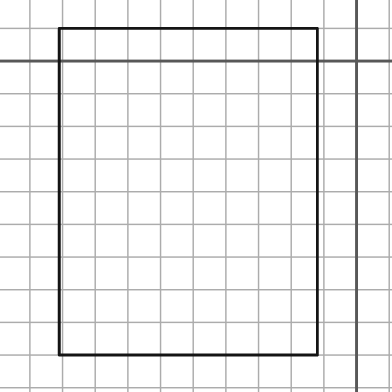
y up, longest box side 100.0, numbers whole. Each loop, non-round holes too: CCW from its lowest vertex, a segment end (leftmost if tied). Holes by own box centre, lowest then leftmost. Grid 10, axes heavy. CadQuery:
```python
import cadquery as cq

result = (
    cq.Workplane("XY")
    .moveTo(-91.0, -90.0)
    .lineTo(-12.0, -90.0)
    .lineTo(-12.0, 10.0)
    .lineTo(-91.0, 10.0)
    .close()
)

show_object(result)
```